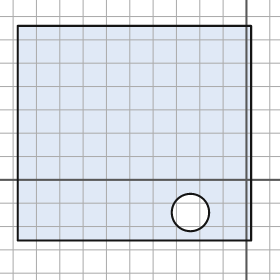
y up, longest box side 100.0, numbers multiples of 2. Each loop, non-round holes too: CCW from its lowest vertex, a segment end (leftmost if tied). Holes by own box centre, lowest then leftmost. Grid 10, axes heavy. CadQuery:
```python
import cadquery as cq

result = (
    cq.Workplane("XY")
    .moveTo(-98.0, -26.0)
    .lineTo(2.0, -26.0)
    .lineTo(2.0, 66.0)
    .lineTo(-98.0, 66.0)
    .close()
    .moveTo(-24.0, -14.0)
    .circle(8.0)
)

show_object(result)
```